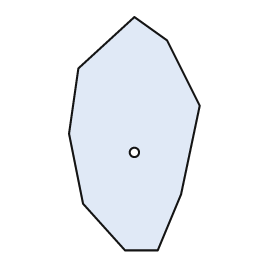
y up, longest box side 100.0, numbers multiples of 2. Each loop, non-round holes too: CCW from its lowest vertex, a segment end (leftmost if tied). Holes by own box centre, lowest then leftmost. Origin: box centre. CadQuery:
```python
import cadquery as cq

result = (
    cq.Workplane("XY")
    .moveTo(-4.0, -50.0)
    .lineTo(10.0, -50.0)
    .lineTo(20.0, -26.0)
    .lineTo(28.0, 12.0)
    .lineTo(14.0, 40.0)
    .lineTo(0.0, 50.0)
    .lineTo(-24.0, 28.0)
    .lineTo(-28.0, 0.0)
    .lineTo(-22.0, -30.0)
    .close()
    .moveTo(0.0, -8.0)
    .circle(2.0)
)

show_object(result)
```